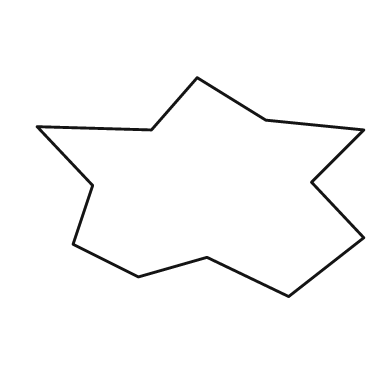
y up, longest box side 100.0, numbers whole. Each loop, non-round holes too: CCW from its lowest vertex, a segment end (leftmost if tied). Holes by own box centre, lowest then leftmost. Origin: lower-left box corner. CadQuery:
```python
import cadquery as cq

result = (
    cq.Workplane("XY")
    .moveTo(77.0, 0.0)
    .lineTo(100.0, 18.0)
    .lineTo(84.0, 35.0)
    .lineTo(100.0, 51.0)
    .lineTo(70.0, 54.0)
    .lineTo(49.0, 67.0)
    .lineTo(35.0, 51.0)
    .lineTo(0.0, 52.0)
    .lineTo(17.0, 34.0)
    .lineTo(11.0, 16.0)
    .lineTo(31.0, 6.0)
    .lineTo(52.0, 12.0)
    .close()
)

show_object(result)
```